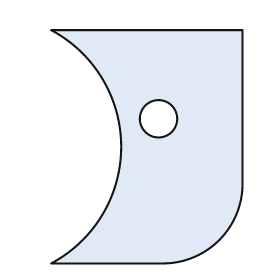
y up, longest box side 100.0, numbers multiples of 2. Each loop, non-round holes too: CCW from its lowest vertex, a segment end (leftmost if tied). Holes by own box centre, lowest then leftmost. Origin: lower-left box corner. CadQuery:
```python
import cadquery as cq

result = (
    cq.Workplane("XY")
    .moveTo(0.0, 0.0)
    .lineTo(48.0, 0.0)
    .threePointArc((72.0, 10.0), (82.0, 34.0))
    .lineTo(82.0, 100.0)
    .lineTo(0.0, 100.0)
    .threePointArc((30.0, 50.0), (0.0, 0.0))
    .close()
    .moveTo(46.0, 62.0)
    .circle(8.0)
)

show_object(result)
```